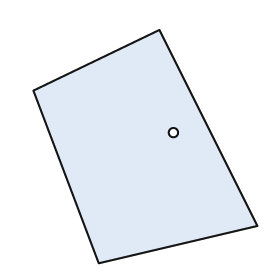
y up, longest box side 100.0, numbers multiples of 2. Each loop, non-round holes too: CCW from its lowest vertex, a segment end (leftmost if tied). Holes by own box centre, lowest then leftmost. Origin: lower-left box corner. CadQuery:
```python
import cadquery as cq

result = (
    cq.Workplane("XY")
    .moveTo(28.0, 0.0)
    .lineTo(96.0, 16.0)
    .lineTo(54.0, 100.0)
    .lineTo(0.0, 74.0)
    .close()
    .moveTo(60.0, 56.0)
    .circle(2.0)
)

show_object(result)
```